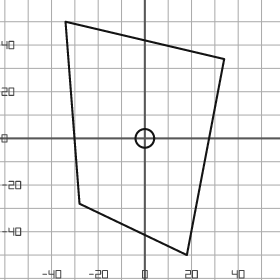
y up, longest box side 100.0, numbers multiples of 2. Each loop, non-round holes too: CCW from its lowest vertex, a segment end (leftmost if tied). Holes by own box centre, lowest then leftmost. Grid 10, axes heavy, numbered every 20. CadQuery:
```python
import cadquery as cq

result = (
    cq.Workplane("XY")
    .moveTo(18.0, -50.0)
    .lineTo(34.0, 34.0)
    .lineTo(-34.0, 50.0)
    .lineTo(-28.0, -28.0)
    .close()
    .moveTo(0.0, 0.0)
    .circle(4.0)
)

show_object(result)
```